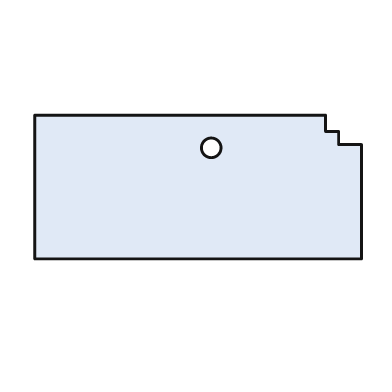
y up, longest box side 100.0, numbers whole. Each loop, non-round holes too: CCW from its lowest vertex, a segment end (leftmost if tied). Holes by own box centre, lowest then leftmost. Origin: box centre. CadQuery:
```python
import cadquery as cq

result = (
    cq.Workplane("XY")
    .moveTo(-50.0, -22.0)
    .lineTo(50.0, -22.0)
    .lineTo(50.0, 13.0)
    .lineTo(43.0, 13.0)
    .lineTo(43.0, 17.0)
    .lineTo(39.0, 17.0)
    .lineTo(39.0, 22.0)
    .lineTo(-50.0, 22.0)
    .close()
    .moveTo(4.0, 12.0)
    .circle(3.0)
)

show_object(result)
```